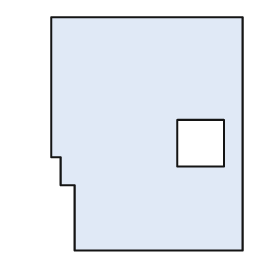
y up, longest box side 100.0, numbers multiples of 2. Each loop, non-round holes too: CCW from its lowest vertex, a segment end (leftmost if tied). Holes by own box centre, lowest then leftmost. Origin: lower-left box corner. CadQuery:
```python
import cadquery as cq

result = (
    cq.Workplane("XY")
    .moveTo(10.0, 0.0)
    .lineTo(82.0, 0.0)
    .lineTo(82.0, 100.0)
    .lineTo(0.0, 100.0)
    .lineTo(0.0, 40.0)
    .lineTo(4.0, 40.0)
    .lineTo(4.0, 28.0)
    .lineTo(10.0, 28.0)
    .close()
    .moveTo(54.0, 36.0)
    .lineTo(74.0, 36.0)
    .lineTo(74.0, 56.0)
    .lineTo(54.0, 56.0)
    .close()
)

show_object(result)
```